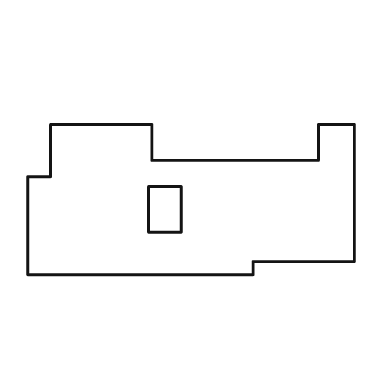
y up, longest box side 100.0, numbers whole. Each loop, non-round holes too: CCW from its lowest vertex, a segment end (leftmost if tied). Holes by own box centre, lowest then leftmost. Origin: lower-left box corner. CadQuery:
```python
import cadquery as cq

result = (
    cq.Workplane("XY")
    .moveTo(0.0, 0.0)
    .lineTo(69.0, 0.0)
    .lineTo(69.0, 4.0)
    .lineTo(100.0, 4.0)
    .lineTo(100.0, 46.0)
    .lineTo(89.0, 46.0)
    .lineTo(89.0, 35.0)
    .lineTo(38.0, 35.0)
    .lineTo(38.0, 46.0)
    .lineTo(7.0, 46.0)
    .lineTo(7.0, 30.0)
    .lineTo(0.0, 30.0)
    .close()
    .moveTo(37.0, 13.0)
    .lineTo(47.0, 13.0)
    .lineTo(47.0, 27.0)
    .lineTo(37.0, 27.0)
    .close()
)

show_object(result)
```